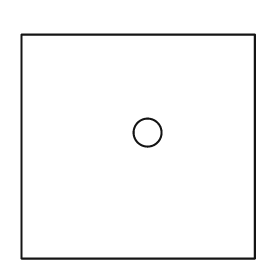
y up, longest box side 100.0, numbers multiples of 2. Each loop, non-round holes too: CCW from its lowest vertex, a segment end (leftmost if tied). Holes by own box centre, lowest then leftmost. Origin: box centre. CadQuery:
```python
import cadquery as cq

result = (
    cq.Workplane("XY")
    .moveTo(-50.0, -48.0)
    .lineTo(50.0, -48.0)
    .lineTo(50.0, 48.0)
    .lineTo(-50.0, 48.0)
    .close()
    .moveTo(4.0, 6.0)
    .circle(6.0)
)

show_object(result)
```